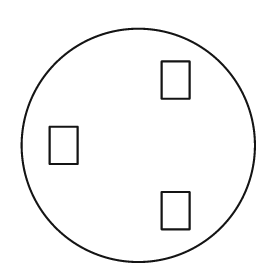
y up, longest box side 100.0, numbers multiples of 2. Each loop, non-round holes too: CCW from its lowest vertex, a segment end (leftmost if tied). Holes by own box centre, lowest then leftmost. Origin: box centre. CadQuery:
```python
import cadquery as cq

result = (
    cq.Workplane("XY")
    .moveTo(0.0, 0.0)
    .circle(50.0)
    .moveTo(10.0, -36.0)
    .lineTo(22.0, -36.0)
    .lineTo(22.0, -20.0)
    .lineTo(10.0, -20.0)
    .close()
    .moveTo(-38.0, -8.0)
    .lineTo(-26.0, -8.0)
    .lineTo(-26.0, 8.0)
    .lineTo(-38.0, 8.0)
    .close()
    .moveTo(10.0, 20.0)
    .lineTo(22.0, 20.0)
    .lineTo(22.0, 36.0)
    .lineTo(10.0, 36.0)
    .close()
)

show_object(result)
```